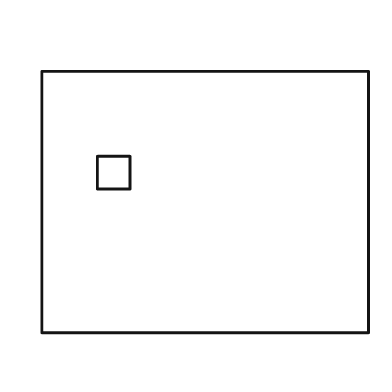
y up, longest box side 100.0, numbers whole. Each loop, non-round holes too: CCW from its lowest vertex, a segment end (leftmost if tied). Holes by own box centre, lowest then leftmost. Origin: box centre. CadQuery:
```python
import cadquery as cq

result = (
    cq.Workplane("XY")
    .moveTo(-50.0, -40.0)
    .lineTo(50.0, -40.0)
    .lineTo(50.0, 40.0)
    .lineTo(-50.0, 40.0)
    .close()
    .moveTo(-33.0, 4.0)
    .lineTo(-23.0, 4.0)
    .lineTo(-23.0, 14.0)
    .lineTo(-33.0, 14.0)
    .close()
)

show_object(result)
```